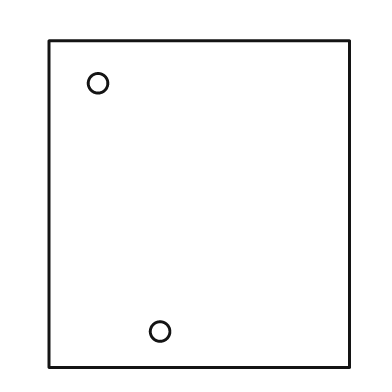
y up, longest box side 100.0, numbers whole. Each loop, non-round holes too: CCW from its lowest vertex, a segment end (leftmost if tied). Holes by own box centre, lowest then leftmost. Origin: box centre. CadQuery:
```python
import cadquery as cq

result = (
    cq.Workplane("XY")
    .moveTo(-46.0, -50.0)
    .lineTo(46.0, -50.0)
    .lineTo(46.0, 50.0)
    .lineTo(-46.0, 50.0)
    .close()
    .moveTo(-12.0, -39.0)
    .circle(3.0)
    .moveTo(-31.0, 37.0)
    .circle(3.0)
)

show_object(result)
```